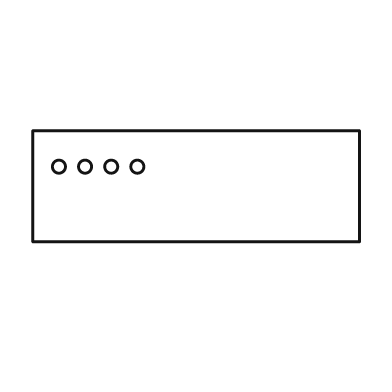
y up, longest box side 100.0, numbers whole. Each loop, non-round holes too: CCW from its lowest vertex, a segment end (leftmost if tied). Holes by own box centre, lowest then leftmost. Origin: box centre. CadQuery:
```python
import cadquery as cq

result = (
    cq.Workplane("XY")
    .moveTo(-50.0, -17.0)
    .lineTo(50.0, -17.0)
    .lineTo(50.0, 17.0)
    .lineTo(-50.0, 17.0)
    .close()
    .moveTo(-42.0, 6.0)
    .circle(2.0)
    .moveTo(-34.0, 6.0)
    .circle(2.0)
    .moveTo(-26.0, 6.0)
    .circle(2.0)
    .moveTo(-18.0, 6.0)
    .circle(2.0)
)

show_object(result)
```